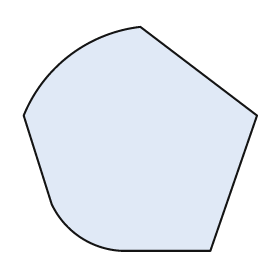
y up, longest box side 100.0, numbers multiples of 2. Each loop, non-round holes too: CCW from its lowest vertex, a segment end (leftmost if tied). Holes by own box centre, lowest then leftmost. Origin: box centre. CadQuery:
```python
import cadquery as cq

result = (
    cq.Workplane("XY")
    .moveTo(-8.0, -48.0)
    .lineTo(30.0, -48.0)
    .lineTo(50.0, 10.0)
    .lineTo(0.0, 48.0)
    .threePointArc((-30.0, 36.0), (-50.0, 10.0))
    .lineTo(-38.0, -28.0)
    .threePointArc((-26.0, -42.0), (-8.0, -48.0))
    .close()
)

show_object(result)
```